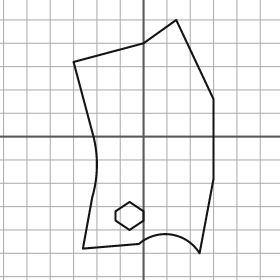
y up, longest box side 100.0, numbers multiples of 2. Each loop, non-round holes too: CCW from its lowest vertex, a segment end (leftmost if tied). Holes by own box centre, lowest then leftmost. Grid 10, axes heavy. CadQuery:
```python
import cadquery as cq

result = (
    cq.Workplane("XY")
    .moveTo(24.0, -50.0)
    .lineTo(30.0, -18.0)
    .lineTo(30.0, 16.0)
    .lineTo(14.0, 50.0)
    .lineTo(0.0, 40.0)
    .lineTo(-30.0, 32.0)
    .lineTo(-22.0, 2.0)
    .threePointArc((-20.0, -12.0), (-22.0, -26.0))
    .lineTo(-26.0, -48.0)
    .lineTo(-2.0, -46.0)
    .threePointArc((12.0, -42.0), (24.0, -50.0))
    .close()
    .moveTo(-6.0, -40.0)
    .lineTo(0.0, -36.0)
    .lineTo(0.0, -32.0)
    .lineTo(-6.0, -28.0)
    .lineTo(-12.0, -32.0)
    .lineTo(-12.0, -36.0)
    .close()
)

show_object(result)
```